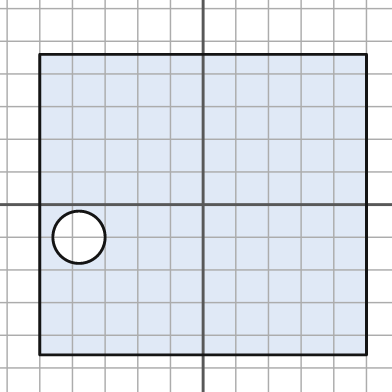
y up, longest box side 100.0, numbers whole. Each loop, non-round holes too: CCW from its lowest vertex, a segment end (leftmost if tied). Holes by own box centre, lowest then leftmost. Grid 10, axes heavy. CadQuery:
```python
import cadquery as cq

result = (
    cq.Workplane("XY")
    .moveTo(-50.0, -46.0)
    .lineTo(50.0, -46.0)
    .lineTo(50.0, 46.0)
    .lineTo(-50.0, 46.0)
    .close()
    .moveTo(-38.0, -10.0)
    .circle(8.0)
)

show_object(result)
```